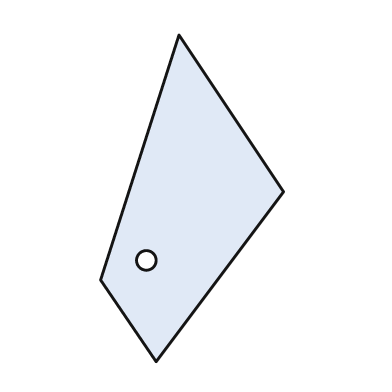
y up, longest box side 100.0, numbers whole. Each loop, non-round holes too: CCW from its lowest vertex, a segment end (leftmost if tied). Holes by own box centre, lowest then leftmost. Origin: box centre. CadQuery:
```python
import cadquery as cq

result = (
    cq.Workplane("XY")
    .moveTo(-11.0, -50.0)
    .lineTo(28.0, 2.0)
    .lineTo(-4.0, 50.0)
    .lineTo(-28.0, -25.0)
    .close()
    .moveTo(-14.0, -19.0)
    .circle(3.0)
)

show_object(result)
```